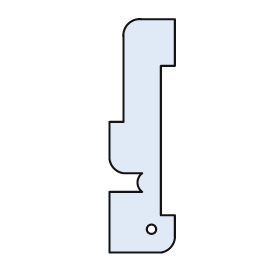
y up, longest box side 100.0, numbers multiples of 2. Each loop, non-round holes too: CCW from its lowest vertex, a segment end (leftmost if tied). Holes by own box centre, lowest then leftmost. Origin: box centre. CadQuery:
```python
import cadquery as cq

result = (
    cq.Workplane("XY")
    .moveTo(-14.0, -50.0)
    .lineTo(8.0, -50.0)
    .threePointArc((12.0, -48.0), (14.0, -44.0))
    .lineTo(14.0, -34.0)
    .lineTo(8.0, -34.0)
    .lineTo(8.0, 30.0)
    .lineTo(14.0, 30.0)
    .lineTo(14.0, 50.0)
    .lineTo(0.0, 50.0)
    .threePointArc((-6.0, 48.0), (-8.0, 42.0))
    .lineTo(-8.0, 6.0)
    .lineTo(-14.0, 6.0)
    .lineTo(-14.0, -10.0)
    .threePointArc((-12.0, -14.0), (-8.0, -16.0))
    .lineTo(0.0, -16.0)
    .threePointArc((-2.0, -20.0), (0.0, -24.0))
    .lineTo(-14.0, -24.0)
    .close()
    .moveTo(4.0, -40.0)
    .circle(2.0)
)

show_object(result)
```